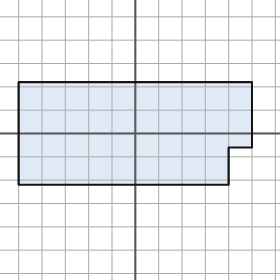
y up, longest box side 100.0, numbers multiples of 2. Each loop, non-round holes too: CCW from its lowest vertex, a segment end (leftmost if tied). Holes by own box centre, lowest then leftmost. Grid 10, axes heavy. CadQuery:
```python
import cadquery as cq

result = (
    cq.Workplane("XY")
    .moveTo(-50.0, -22.0)
    .lineTo(40.0, -22.0)
    .lineTo(40.0, -6.0)
    .lineTo(50.0, -6.0)
    .lineTo(50.0, 22.0)
    .lineTo(-50.0, 22.0)
    .close()
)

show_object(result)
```